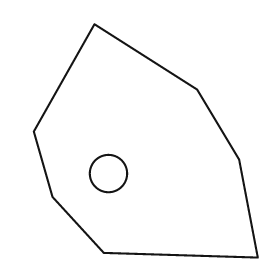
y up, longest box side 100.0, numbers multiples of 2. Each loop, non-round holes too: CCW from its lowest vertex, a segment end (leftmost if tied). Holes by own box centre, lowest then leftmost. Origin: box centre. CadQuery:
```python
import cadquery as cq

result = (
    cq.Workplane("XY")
    .moveTo(48.0, -50.0)
    .lineTo(40.0, -8.0)
    .lineTo(22.0, 22.0)
    .lineTo(-22.0, 50.0)
    .lineTo(-48.0, 4.0)
    .lineTo(-40.0, -24.0)
    .lineTo(-18.0, -48.0)
    .close()
    .moveTo(-16.0, -14.0)
    .circle(8.0)
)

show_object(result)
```